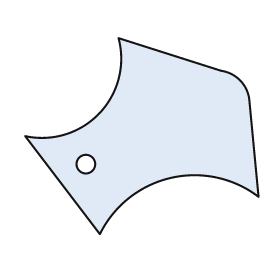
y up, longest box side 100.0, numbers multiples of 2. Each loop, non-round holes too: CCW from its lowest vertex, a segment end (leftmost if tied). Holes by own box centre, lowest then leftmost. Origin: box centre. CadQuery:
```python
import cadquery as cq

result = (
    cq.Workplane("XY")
    .moveTo(-18.0, -42.0)
    .threePointArc((12.0, -18.0), (50.0, -26.0))
    .lineTo(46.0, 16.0)
    .threePointArc((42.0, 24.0), (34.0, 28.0))
    .lineTo(-10.0, 42.0)
    .threePointArc((-18.0, 10.0), (-50.0, 0.0))
    .close()
    .moveTo(-24.0, -12.0)
    .circle(4.0)
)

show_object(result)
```